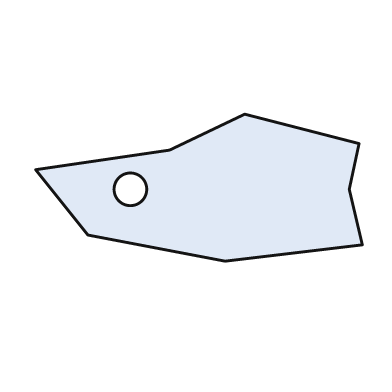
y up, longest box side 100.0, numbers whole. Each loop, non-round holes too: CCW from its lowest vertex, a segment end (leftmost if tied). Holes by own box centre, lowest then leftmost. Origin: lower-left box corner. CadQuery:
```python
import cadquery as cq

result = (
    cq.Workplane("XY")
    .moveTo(58.0, 0.0)
    .lineTo(100.0, 5.0)
    .lineTo(96.0, 22.0)
    .lineTo(99.0, 36.0)
    .lineTo(64.0, 45.0)
    .lineTo(41.0, 34.0)
    .lineTo(0.0, 28.0)
    .lineTo(16.0, 8.0)
    .close()
    .moveTo(29.0, 22.0)
    .circle(5.0)
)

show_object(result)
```